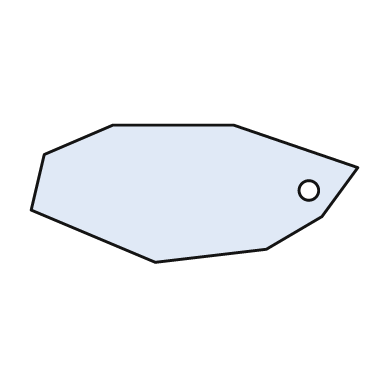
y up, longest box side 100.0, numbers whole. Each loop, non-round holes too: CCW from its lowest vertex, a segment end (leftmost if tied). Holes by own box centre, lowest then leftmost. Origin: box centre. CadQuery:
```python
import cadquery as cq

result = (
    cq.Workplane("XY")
    .moveTo(-12.0, -21.0)
    .lineTo(22.0, -17.0)
    .lineTo(39.0, -7.0)
    .lineTo(50.0, 8.0)
    .lineTo(12.0, 21.0)
    .lineTo(-25.0, 21.0)
    .lineTo(-46.0, 12.0)
    .lineTo(-50.0, -5.0)
    .close()
    .moveTo(35.0, 1.0)
    .circle(3.0)
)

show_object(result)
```